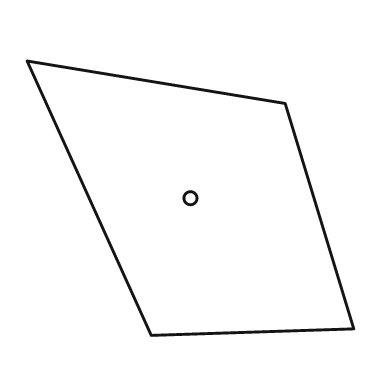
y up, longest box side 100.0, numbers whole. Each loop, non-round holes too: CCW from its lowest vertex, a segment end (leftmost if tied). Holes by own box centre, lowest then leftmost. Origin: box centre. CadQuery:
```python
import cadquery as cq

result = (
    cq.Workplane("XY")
    .moveTo(-12.0, -42.0)
    .lineTo(50.0, -40.0)
    .lineTo(29.0, 29.0)
    .lineTo(-50.0, 42.0)
    .close()
    .moveTo(0.0, 0.0)
    .circle(2.0)
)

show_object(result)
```